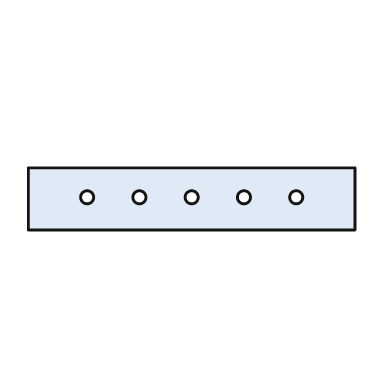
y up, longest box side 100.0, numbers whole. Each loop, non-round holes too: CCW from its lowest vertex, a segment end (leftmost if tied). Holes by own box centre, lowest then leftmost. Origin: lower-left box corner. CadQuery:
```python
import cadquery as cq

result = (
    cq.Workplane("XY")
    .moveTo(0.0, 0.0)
    .lineTo(100.0, 0.0)
    .lineTo(100.0, 19.0)
    .lineTo(0.0, 19.0)
    .close()
    .moveTo(18.0, 10.0)
    .circle(2.0)
    .moveTo(34.0, 10.0)
    .circle(2.0)
    .moveTo(50.0, 10.0)
    .circle(2.0)
    .moveTo(66.0, 10.0)
    .circle(2.0)
    .moveTo(82.0, 10.0)
    .circle(2.0)
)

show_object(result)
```